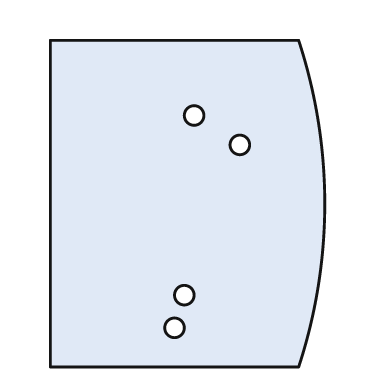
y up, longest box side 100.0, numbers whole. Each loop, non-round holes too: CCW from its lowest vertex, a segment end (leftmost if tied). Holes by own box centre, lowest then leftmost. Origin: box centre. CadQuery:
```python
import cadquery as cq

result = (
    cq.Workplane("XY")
    .moveTo(-42.0, -50.0)
    .lineTo(34.0, -50.0)
    .threePointArc((42.0, 0.0), (34.0, 50.0))
    .lineTo(-42.0, 50.0)
    .close()
    .moveTo(-4.0, -38.0)
    .circle(3.0)
    .moveTo(-1.0, -28.0)
    .circle(3.0)
    .moveTo(16.0, 18.0)
    .circle(3.0)
    .moveTo(2.0, 27.0)
    .circle(3.0)
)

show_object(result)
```